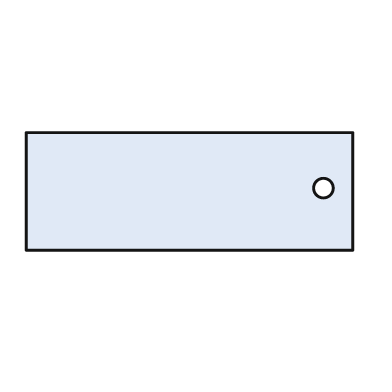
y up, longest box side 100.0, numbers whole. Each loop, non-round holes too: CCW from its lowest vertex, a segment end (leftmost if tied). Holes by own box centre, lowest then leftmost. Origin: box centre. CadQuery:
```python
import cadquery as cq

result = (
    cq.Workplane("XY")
    .moveTo(-50.0, -18.0)
    .lineTo(50.0, -18.0)
    .lineTo(50.0, 18.0)
    .lineTo(-50.0, 18.0)
    .close()
    .moveTo(41.0, 1.0)
    .circle(3.0)
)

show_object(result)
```